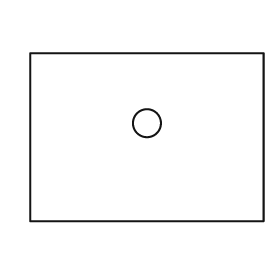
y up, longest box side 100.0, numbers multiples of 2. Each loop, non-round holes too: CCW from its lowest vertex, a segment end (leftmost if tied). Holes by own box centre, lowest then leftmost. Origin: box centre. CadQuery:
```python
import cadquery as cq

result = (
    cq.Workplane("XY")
    .moveTo(-50.0, -36.0)
    .lineTo(50.0, -36.0)
    .lineTo(50.0, 36.0)
    .lineTo(-50.0, 36.0)
    .close()
    .moveTo(0.0, 6.0)
    .circle(6.0)
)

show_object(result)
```